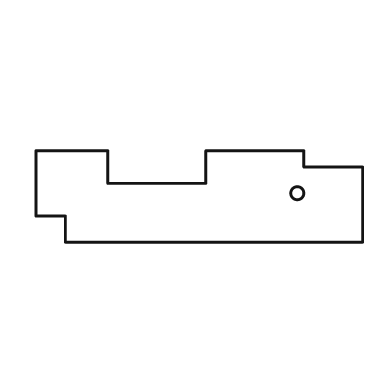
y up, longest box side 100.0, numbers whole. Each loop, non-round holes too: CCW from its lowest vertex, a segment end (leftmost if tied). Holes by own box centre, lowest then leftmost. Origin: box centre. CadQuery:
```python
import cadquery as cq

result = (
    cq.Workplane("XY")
    .moveTo(-41.0, -14.0)
    .lineTo(50.0, -14.0)
    .lineTo(50.0, 9.0)
    .lineTo(32.0, 9.0)
    .lineTo(32.0, 14.0)
    .lineTo(2.0, 14.0)
    .lineTo(2.0, 4.0)
    .lineTo(-28.0, 4.0)
    .lineTo(-28.0, 14.0)
    .lineTo(-50.0, 14.0)
    .lineTo(-50.0, -6.0)
    .lineTo(-41.0, -6.0)
    .close()
    .moveTo(30.0, 1.0)
    .circle(2.0)
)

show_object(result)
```